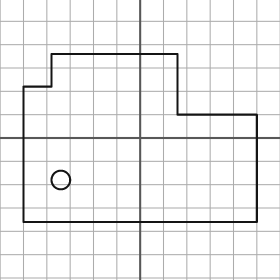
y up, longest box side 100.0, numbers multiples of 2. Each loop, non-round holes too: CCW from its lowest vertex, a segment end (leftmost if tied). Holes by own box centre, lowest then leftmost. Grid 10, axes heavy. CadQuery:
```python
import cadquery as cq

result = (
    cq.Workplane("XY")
    .moveTo(-50.0, -36.0)
    .lineTo(50.0, -36.0)
    .lineTo(50.0, 10.0)
    .lineTo(16.0, 10.0)
    .lineTo(16.0, 36.0)
    .lineTo(-38.0, 36.0)
    .lineTo(-38.0, 22.0)
    .lineTo(-50.0, 22.0)
    .close()
    .moveTo(-34.0, -18.0)
    .circle(4.0)
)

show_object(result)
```